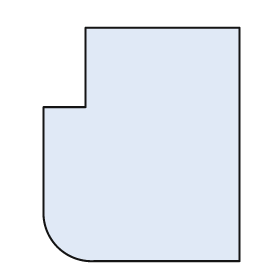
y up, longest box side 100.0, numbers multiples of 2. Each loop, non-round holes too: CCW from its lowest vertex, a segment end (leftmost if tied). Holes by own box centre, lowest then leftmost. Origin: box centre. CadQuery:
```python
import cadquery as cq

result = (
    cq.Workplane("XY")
    .moveTo(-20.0, -50.0)
    .lineTo(42.0, -50.0)
    .lineTo(42.0, 50.0)
    .lineTo(-24.0, 50.0)
    .lineTo(-24.0, 16.0)
    .lineTo(-42.0, 16.0)
    .lineTo(-42.0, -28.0)
    .threePointArc((-36.0, -44.0), (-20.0, -50.0))
    .close()
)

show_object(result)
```